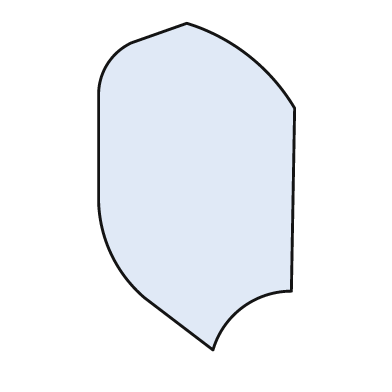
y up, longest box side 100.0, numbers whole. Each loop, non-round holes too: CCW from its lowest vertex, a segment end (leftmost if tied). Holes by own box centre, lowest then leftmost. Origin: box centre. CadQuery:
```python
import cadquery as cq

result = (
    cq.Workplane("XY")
    .moveTo(5.0, -50.0)
    .threePointArc((14.0, -37.0), (29.0, -32.0))
    .lineTo(30.0, 24.0)
    .threePointArc((16.0, 40.0), (-3.0, 50.0))
    .lineTo(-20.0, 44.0)
    .threePointArc((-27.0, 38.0), (-30.0, 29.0))
    .lineTo(-30.0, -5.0)
    .threePointArc((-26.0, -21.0), (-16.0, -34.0))
    .close()
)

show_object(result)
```